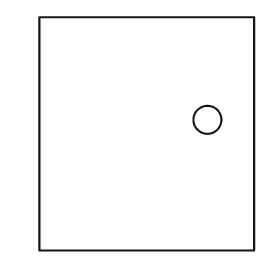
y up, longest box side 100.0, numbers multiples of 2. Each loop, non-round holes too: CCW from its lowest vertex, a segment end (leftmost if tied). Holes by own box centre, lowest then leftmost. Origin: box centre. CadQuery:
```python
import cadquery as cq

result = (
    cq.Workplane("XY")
    .moveTo(-46.0, -50.0)
    .lineTo(46.0, -50.0)
    .lineTo(46.0, 50.0)
    .lineTo(-46.0, 50.0)
    .close()
    .moveTo(26.0, 6.0)
    .circle(6.0)
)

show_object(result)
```